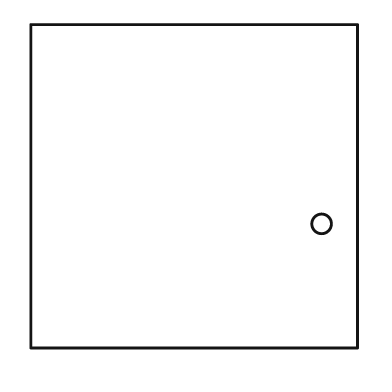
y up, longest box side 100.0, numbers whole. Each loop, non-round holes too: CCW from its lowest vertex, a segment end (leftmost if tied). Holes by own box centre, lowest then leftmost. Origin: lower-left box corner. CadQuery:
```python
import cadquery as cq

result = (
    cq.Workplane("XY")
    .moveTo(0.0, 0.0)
    .lineTo(100.0, 0.0)
    .lineTo(100.0, 99.0)
    .lineTo(0.0, 99.0)
    .close()
    .moveTo(89.0, 38.0)
    .circle(3.0)
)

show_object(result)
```